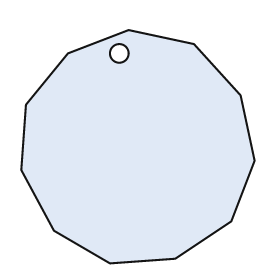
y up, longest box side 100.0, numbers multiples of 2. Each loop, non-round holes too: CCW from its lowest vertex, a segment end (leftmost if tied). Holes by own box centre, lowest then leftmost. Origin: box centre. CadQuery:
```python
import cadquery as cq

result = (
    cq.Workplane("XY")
    .moveTo(-12.0, -50.0)
    .lineTo(16.0, -48.0)
    .lineTo(40.0, -32.0)
    .lineTo(50.0, -6.0)
    .lineTo(44.0, 22.0)
    .lineTo(24.0, 44.0)
    .lineTo(-4.0, 50.0)
    .lineTo(-30.0, 40.0)
    .lineTo(-48.0, 18.0)
    .lineTo(-50.0, -10.0)
    .lineTo(-36.0, -36.0)
    .close()
    .moveTo(-8.0, 40.0)
    .circle(4.0)
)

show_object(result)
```